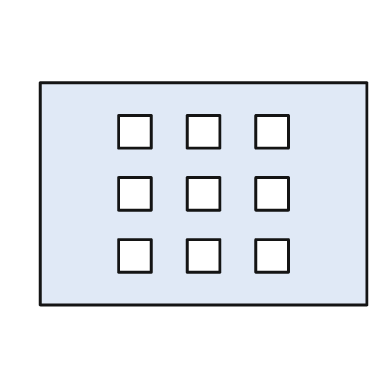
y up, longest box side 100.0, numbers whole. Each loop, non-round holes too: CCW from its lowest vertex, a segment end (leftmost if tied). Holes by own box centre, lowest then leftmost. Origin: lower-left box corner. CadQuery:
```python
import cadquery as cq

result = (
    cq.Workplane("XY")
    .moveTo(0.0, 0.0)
    .lineTo(100.0, 0.0)
    .lineTo(100.0, 68.0)
    .lineTo(0.0, 68.0)
    .close()
    .moveTo(24.0, 10.0)
    .lineTo(34.0, 10.0)
    .lineTo(34.0, 20.0)
    .lineTo(24.0, 20.0)
    .close()
    .moveTo(45.0, 10.0)
    .lineTo(55.0, 10.0)
    .lineTo(55.0, 20.0)
    .lineTo(45.0, 20.0)
    .close()
    .moveTo(66.0, 10.0)
    .lineTo(76.0, 10.0)
    .lineTo(76.0, 20.0)
    .lineTo(66.0, 20.0)
    .close()
    .moveTo(24.0, 29.0)
    .lineTo(34.0, 29.0)
    .lineTo(34.0, 39.0)
    .lineTo(24.0, 39.0)
    .close()
    .moveTo(45.0, 29.0)
    .lineTo(55.0, 29.0)
    .lineTo(55.0, 39.0)
    .lineTo(45.0, 39.0)
    .close()
    .moveTo(66.0, 29.0)
    .lineTo(76.0, 29.0)
    .lineTo(76.0, 39.0)
    .lineTo(66.0, 39.0)
    .close()
    .moveTo(24.0, 48.0)
    .lineTo(34.0, 48.0)
    .lineTo(34.0, 58.0)
    .lineTo(24.0, 58.0)
    .close()
    .moveTo(45.0, 48.0)
    .lineTo(55.0, 48.0)
    .lineTo(55.0, 58.0)
    .lineTo(45.0, 58.0)
    .close()
    .moveTo(66.0, 48.0)
    .lineTo(76.0, 48.0)
    .lineTo(76.0, 58.0)
    .lineTo(66.0, 58.0)
    .close()
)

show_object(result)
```